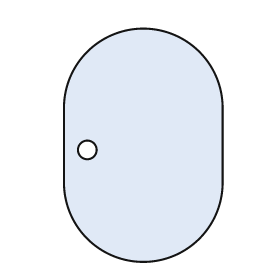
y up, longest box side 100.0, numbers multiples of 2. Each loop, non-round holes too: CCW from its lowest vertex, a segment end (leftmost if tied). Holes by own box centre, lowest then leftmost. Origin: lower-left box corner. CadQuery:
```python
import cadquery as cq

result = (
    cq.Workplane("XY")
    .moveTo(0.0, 34.0)
    .threePointArc((34.0, 0.0), (68.0, 34.0))
    .lineTo(68.0, 66.0)
    .threePointArc((34.0, 100.0), (0.0, 66.0))
    .close()
    .moveTo(10.0, 48.0)
    .circle(4.0)
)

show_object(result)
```